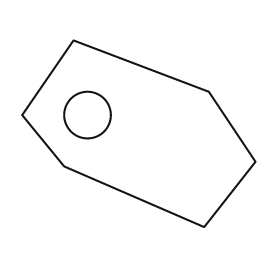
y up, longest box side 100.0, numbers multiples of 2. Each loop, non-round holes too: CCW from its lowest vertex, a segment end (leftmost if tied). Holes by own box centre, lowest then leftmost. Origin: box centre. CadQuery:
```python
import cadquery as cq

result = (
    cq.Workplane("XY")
    .moveTo(28.0, -40.0)
    .lineTo(50.0, -12.0)
    .lineTo(30.0, 18.0)
    .lineTo(-28.0, 40.0)
    .lineTo(-50.0, 8.0)
    .lineTo(-32.0, -14.0)
    .close()
    .moveTo(-22.0, 8.0)
    .circle(10.0)
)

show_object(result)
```